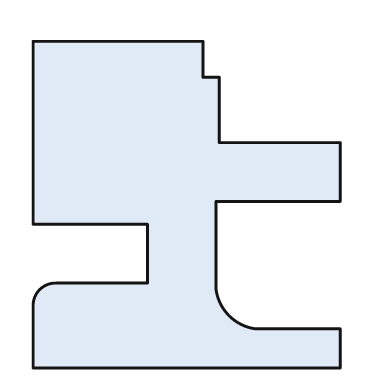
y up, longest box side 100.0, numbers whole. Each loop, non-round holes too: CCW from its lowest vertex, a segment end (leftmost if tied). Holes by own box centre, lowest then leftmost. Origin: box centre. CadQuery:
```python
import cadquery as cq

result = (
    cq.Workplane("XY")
    .moveTo(-47.0, -50.0)
    .lineTo(47.0, -50.0)
    .lineTo(47.0, -38.0)
    .lineTo(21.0, -38.0)
    .threePointArc((13.0, -34.0), (9.0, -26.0))
    .lineTo(9.0, 1.0)
    .lineTo(47.0, 1.0)
    .lineTo(47.0, 19.0)
    .lineTo(10.0, 19.0)
    .lineTo(10.0, 39.0)
    .lineTo(5.0, 39.0)
    .lineTo(5.0, 50.0)
    .lineTo(-47.0, 50.0)
    .lineTo(-47.0, -6.0)
    .lineTo(-12.0, -6.0)
    .lineTo(-12.0, -24.0)
    .lineTo(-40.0, -24.0)
    .threePointArc((-45.0, -26.0), (-47.0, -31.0))
    .close()
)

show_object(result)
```